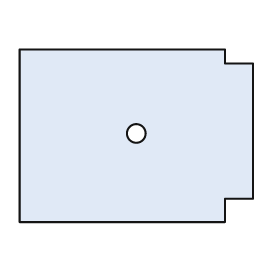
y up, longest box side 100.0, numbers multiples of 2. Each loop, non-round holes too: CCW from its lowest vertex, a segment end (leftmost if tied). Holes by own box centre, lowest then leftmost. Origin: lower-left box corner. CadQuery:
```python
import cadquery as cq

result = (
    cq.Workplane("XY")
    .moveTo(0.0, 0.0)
    .lineTo(88.0, 0.0)
    .lineTo(88.0, 10.0)
    .lineTo(100.0, 10.0)
    .lineTo(100.0, 68.0)
    .lineTo(88.0, 68.0)
    .lineTo(88.0, 74.0)
    .lineTo(0.0, 74.0)
    .close()
    .moveTo(50.0, 38.0)
    .circle(4.0)
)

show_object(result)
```